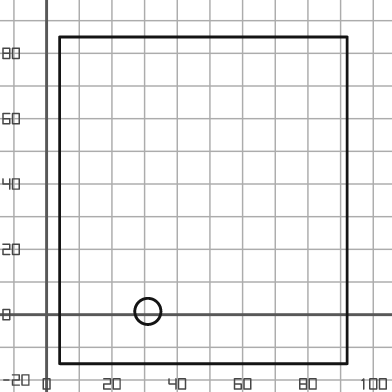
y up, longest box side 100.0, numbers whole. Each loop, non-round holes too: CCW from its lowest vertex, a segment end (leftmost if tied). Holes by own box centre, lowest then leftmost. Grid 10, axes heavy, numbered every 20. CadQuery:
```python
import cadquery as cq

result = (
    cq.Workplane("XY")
    .moveTo(4.0, -15.0)
    .lineTo(92.0, -15.0)
    .lineTo(92.0, 85.0)
    .lineTo(4.0, 85.0)
    .close()
    .moveTo(31.0, 1.0)
    .circle(4.0)
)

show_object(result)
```